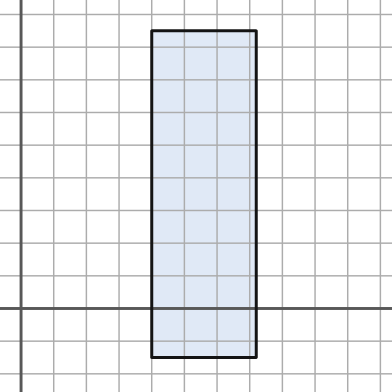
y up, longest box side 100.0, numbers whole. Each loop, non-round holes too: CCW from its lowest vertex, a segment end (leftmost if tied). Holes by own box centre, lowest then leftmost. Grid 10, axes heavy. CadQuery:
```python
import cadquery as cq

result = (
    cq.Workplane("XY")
    .moveTo(40.0, -15.0)
    .lineTo(72.0, -15.0)
    .lineTo(72.0, 85.0)
    .lineTo(40.0, 85.0)
    .close()
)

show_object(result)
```